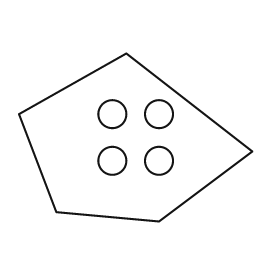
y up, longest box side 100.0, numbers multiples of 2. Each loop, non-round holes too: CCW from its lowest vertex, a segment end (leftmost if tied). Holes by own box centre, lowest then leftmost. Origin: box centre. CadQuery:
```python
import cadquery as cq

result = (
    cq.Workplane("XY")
    .moveTo(10.0, -36.0)
    .lineTo(50.0, -6.0)
    .lineTo(-4.0, 36.0)
    .lineTo(-50.0, 10.0)
    .lineTo(-34.0, -32.0)
    .close()
    .moveTo(-10.0, -10.0)
    .circle(6.0)
    .moveTo(10.0, -10.0)
    .circle(6.0)
    .moveTo(-10.0, 10.0)
    .circle(6.0)
    .moveTo(10.0, 10.0)
    .circle(6.0)
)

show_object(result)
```